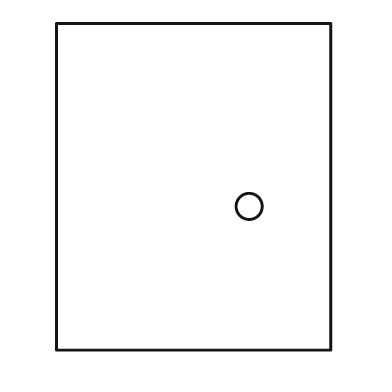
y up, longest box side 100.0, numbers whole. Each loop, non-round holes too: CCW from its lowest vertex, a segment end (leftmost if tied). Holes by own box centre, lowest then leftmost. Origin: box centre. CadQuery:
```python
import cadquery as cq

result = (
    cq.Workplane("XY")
    .moveTo(-42.0, -50.0)
    .lineTo(42.0, -50.0)
    .lineTo(42.0, 50.0)
    .lineTo(-42.0, 50.0)
    .close()
    .moveTo(17.0, -6.0)
    .circle(4.0)
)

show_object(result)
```